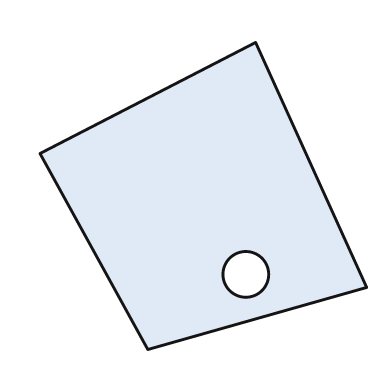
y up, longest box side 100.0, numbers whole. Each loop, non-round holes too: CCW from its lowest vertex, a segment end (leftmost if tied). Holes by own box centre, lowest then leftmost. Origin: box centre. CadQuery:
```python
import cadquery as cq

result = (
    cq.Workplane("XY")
    .moveTo(-17.0, -47.0)
    .lineTo(50.0, -28.0)
    .lineTo(16.0, 47.0)
    .lineTo(-50.0, 13.0)
    .close()
    .moveTo(13.0, -24.0)
    .circle(7.0)
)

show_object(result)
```